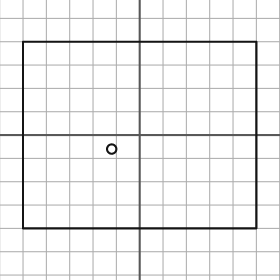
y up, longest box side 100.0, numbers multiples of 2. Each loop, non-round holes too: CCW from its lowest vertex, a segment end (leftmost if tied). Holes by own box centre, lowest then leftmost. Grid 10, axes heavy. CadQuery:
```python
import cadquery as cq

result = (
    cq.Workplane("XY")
    .moveTo(-50.0, -40.0)
    .lineTo(50.0, -40.0)
    .lineTo(50.0, 40.0)
    .lineTo(-50.0, 40.0)
    .close()
    .moveTo(-12.0, -6.0)
    .circle(2.0)
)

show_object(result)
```